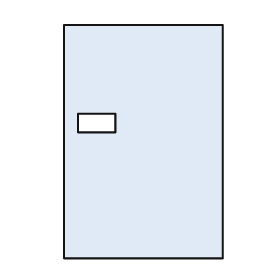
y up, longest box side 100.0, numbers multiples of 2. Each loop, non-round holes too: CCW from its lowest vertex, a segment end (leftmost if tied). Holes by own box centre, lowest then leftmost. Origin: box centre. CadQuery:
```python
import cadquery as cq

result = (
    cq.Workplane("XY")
    .moveTo(-34.0, -50.0)
    .lineTo(34.0, -50.0)
    .lineTo(34.0, 50.0)
    .lineTo(-34.0, 50.0)
    .close()
    .moveTo(-28.0, 4.0)
    .lineTo(-12.0, 4.0)
    .lineTo(-12.0, 12.0)
    .lineTo(-28.0, 12.0)
    .close()
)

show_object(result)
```